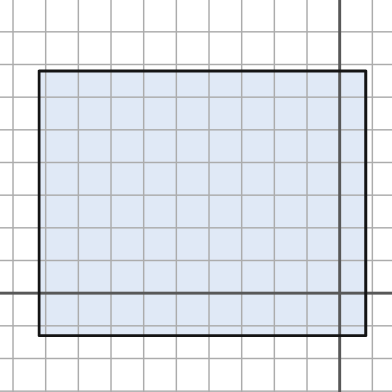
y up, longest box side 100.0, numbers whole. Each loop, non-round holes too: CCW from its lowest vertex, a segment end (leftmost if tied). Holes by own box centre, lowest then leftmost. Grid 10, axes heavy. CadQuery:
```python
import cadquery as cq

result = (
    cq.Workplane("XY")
    .moveTo(-92.0, -13.0)
    .lineTo(8.0, -13.0)
    .lineTo(8.0, 68.0)
    .lineTo(-92.0, 68.0)
    .close()
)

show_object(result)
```